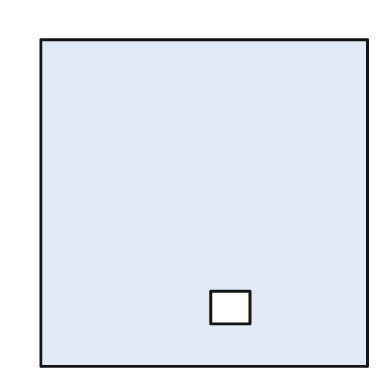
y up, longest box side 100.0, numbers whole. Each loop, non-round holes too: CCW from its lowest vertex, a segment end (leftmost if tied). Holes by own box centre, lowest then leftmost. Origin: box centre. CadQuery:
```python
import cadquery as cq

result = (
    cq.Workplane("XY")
    .moveTo(-50.0, -50.0)
    .lineTo(50.0, -50.0)
    .lineTo(50.0, 50.0)
    .lineTo(-50.0, 50.0)
    .close()
    .moveTo(2.0, -37.0)
    .lineTo(14.0, -37.0)
    .lineTo(14.0, -27.0)
    .lineTo(2.0, -27.0)
    .close()
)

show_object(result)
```